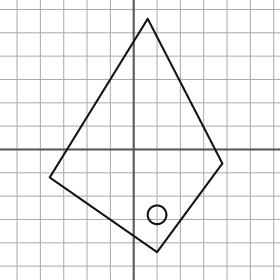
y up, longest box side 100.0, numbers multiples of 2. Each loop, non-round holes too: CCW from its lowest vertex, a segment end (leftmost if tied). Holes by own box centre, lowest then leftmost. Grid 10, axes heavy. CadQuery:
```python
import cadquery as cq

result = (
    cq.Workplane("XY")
    .moveTo(10.0, -44.0)
    .lineTo(38.0, -6.0)
    .lineTo(6.0, 56.0)
    .lineTo(-36.0, -12.0)
    .close()
    .moveTo(10.0, -28.0)
    .circle(4.0)
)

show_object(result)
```